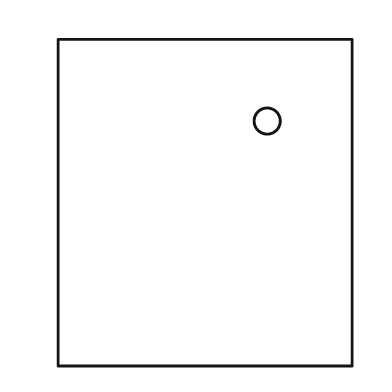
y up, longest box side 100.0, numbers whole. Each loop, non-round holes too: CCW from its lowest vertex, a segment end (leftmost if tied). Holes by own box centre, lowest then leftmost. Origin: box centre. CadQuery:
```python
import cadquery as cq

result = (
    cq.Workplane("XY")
    .moveTo(-45.0, -50.0)
    .lineTo(45.0, -50.0)
    .lineTo(45.0, 50.0)
    .lineTo(-45.0, 50.0)
    .close()
    .moveTo(19.0, 25.0)
    .circle(4.0)
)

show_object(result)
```